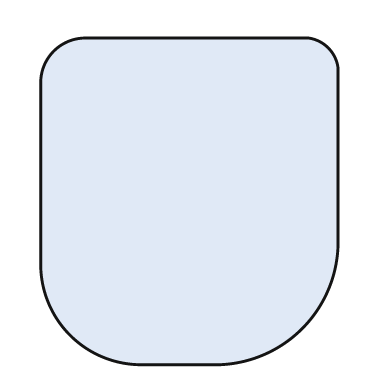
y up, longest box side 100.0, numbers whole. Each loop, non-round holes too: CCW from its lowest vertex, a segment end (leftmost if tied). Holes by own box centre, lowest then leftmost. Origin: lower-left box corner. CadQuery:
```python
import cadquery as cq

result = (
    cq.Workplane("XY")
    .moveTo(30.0, 0.0)
    .lineTo(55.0, 0.0)
    .threePointArc((80.0, 11.0), (91.0, 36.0))
    .lineTo(91.0, 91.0)
    .threePointArc((88.0, 97.0), (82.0, 100.0))
    .lineTo(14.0, 100.0)
    .threePointArc((4.0, 96.0), (0.0, 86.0))
    .lineTo(0.0, 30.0)
    .threePointArc((9.0, 9.0), (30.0, 0.0))
    .close()
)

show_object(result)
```